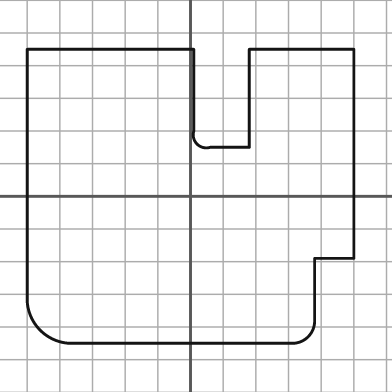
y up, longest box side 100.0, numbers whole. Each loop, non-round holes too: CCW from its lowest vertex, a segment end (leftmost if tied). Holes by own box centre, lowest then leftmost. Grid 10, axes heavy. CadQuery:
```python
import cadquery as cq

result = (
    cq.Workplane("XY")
    .moveTo(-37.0, -45.0)
    .lineTo(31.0, -45.0)
    .threePointArc((36.0, -43.0), (38.0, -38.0))
    .lineTo(38.0, -19.0)
    .lineTo(50.0, -19.0)
    .lineTo(50.0, 45.0)
    .lineTo(18.0, 45.0)
    .lineTo(18.0, 15.0)
    .lineTo(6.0, 15.0)
    .threePointArc((2.0, 16.0), (1.0, 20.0))
    .lineTo(1.0, 45.0)
    .lineTo(-50.0, 45.0)
    .lineTo(-50.0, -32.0)
    .threePointArc((-46.0, -41.0), (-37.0, -45.0))
    .close()
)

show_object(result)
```